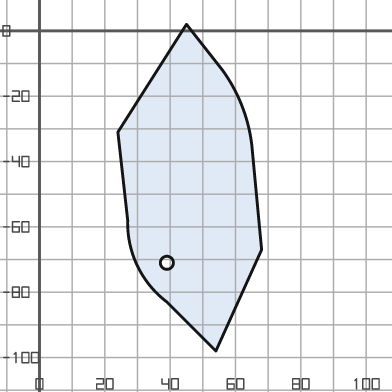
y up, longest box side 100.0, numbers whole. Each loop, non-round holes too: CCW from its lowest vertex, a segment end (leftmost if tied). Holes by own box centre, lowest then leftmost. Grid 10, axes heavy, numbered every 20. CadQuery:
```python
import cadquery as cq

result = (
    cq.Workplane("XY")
    .moveTo(54.0, -98.0)
    .lineTo(68.0, -67.0)
    .lineTo(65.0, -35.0)
    .threePointArc((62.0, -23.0), (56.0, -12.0))
    .lineTo(45.0, 2.0)
    .lineTo(24.0, -31.0)
    .lineTo(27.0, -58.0)
    .threePointArc((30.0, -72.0), (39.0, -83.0))
    .close()
    .moveTo(39.0, -71.0)
    .circle(2.0)
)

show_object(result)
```